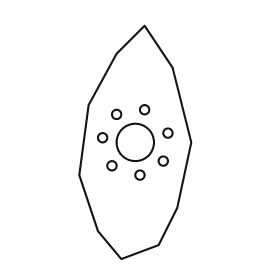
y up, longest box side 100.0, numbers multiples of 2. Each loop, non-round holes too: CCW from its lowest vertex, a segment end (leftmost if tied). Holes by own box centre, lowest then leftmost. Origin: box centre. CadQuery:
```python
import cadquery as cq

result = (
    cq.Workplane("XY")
    .moveTo(-6.0, -50.0)
    .lineTo(10.0, -44.0)
    .lineTo(18.0, -28.0)
    .lineTo(24.0, 0.0)
    .lineTo(16.0, 32.0)
    .lineTo(4.0, 50.0)
    .lineTo(-8.0, 38.0)
    .lineTo(-20.0, 16.0)
    .lineTo(-24.0, -14.0)
    .lineTo(-16.0, -38.0)
    .close()
    .moveTo(2.0, -14.0)
    .circle(2.0)
    .moveTo(-10.0, -10.0)
    .circle(2.0)
    .moveTo(12.0, -8.0)
    .circle(2.0)
    .moveTo(0.0, 0.0)
    .circle(8.0)
    .moveTo(-14.0, 2.0)
    .circle(2.0)
    .moveTo(14.0, 4.0)
    .circle(2.0)
    .moveTo(-8.0, 12.0)
    .circle(2.0)
    .moveTo(4.0, 14.0)
    .circle(2.0)
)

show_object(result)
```